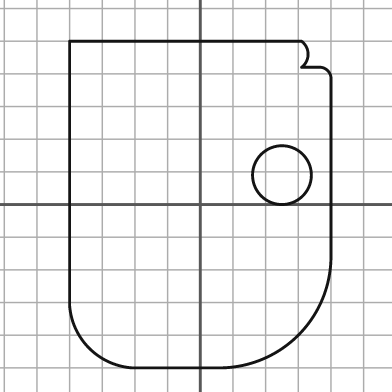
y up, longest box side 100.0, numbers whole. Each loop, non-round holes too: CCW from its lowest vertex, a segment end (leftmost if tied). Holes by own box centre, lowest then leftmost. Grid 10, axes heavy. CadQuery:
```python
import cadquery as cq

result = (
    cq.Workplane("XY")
    .moveTo(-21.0, -50.0)
    .lineTo(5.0, -50.0)
    .threePointArc((30.0, -40.0), (40.0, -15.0))
    .lineTo(40.0, 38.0)
    .threePointArc((39.0, 41.0), (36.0, 42.0))
    .lineTo(31.0, 42.0)
    .threePointArc((33.0, 46.0), (31.0, 50.0))
    .lineTo(-40.0, 50.0)
    .lineTo(-40.0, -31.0)
    .threePointArc((-34.0, -44.0), (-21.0, -50.0))
    .close()
    .moveTo(25.0, 9.0)
    .circle(9.0)
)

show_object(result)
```